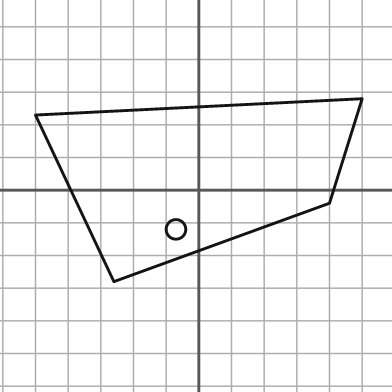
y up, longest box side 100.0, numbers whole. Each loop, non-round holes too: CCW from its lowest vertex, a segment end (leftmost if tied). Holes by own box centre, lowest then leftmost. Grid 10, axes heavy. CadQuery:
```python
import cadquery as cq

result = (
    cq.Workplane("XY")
    .moveTo(-26.0, -28.0)
    .lineTo(40.0, -4.0)
    .lineTo(50.0, 28.0)
    .lineTo(-50.0, 23.0)
    .close()
    .moveTo(-7.0, -12.0)
    .circle(3.0)
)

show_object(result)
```